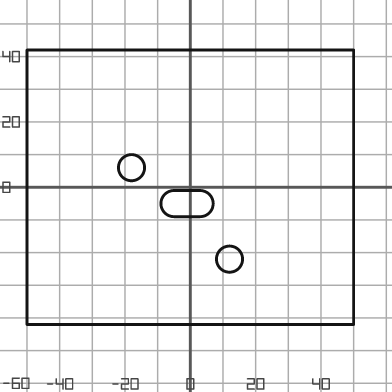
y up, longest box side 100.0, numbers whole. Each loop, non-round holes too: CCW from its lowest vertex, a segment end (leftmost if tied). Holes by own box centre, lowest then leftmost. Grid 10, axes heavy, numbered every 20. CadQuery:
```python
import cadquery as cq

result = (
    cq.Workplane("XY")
    .moveTo(-50.0, -42.0)
    .lineTo(50.0, -42.0)
    .lineTo(50.0, 42.0)
    .lineTo(-50.0, 42.0)
    .close()
    .moveTo(12.0, -22.0)
    .circle(4.0)
    .moveTo(-5.0, -9.0)
    .lineTo(3.0, -9.0)
    .threePointArc((7.0, -5.0), (3.0, -1.0))
    .lineTo(-5.0, -1.0)
    .threePointArc((-9.0, -5.0), (-5.0, -9.0))
    .close()
    .moveTo(-18.0, 6.0)
    .circle(4.0)
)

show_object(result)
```